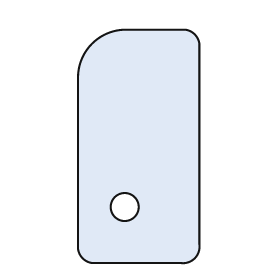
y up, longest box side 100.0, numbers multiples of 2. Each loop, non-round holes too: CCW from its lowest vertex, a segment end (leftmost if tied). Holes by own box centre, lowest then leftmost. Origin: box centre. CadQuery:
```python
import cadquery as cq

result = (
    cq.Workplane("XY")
    .moveTo(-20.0, -50.0)
    .lineTo(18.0, -50.0)
    .threePointArc((24.0, -48.0), (26.0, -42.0))
    .lineTo(26.0, 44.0)
    .threePointArc((24.0, 48.0), (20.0, 50.0))
    .lineTo(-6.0, 50.0)
    .threePointArc((-20.0, 44.0), (-26.0, 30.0))
    .lineTo(-26.0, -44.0)
    .threePointArc((-24.0, -48.0), (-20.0, -50.0))
    .close()
    .moveTo(-6.0, -26.0)
    .circle(6.0)
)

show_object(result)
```